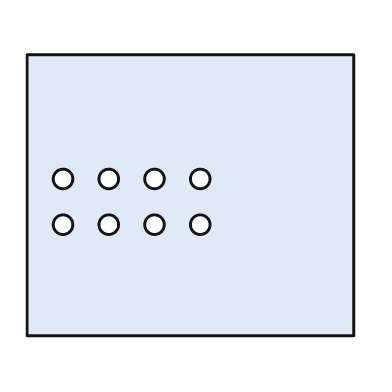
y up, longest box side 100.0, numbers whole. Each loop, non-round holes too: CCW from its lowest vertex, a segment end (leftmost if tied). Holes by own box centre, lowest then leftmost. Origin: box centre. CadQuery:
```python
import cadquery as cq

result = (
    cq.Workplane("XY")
    .moveTo(-50.0, -43.0)
    .lineTo(50.0, -43.0)
    .lineTo(50.0, 43.0)
    .lineTo(-50.0, 43.0)
    .close()
    .moveTo(-39.0, -9.0)
    .circle(3.0)
    .moveTo(-25.0, -9.0)
    .circle(3.0)
    .moveTo(-11.0, -9.0)
    .circle(3.0)
    .moveTo(3.0, -9.0)
    .circle(3.0)
    .moveTo(-39.0, 5.0)
    .circle(3.0)
    .moveTo(-25.0, 5.0)
    .circle(3.0)
    .moveTo(-11.0, 5.0)
    .circle(3.0)
    .moveTo(3.0, 5.0)
    .circle(3.0)
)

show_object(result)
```